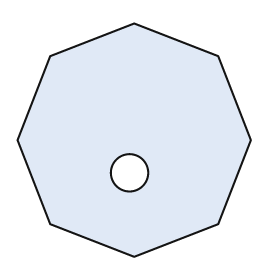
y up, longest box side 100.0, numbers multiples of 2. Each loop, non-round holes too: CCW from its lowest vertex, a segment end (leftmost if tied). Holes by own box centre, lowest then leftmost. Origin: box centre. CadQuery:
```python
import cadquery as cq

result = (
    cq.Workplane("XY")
    .moveTo(0.0, -50.0)
    .lineTo(36.0, -36.0)
    .lineTo(50.0, 0.0)
    .lineTo(36.0, 36.0)
    .lineTo(0.0, 50.0)
    .lineTo(-36.0, 36.0)
    .lineTo(-50.0, 0.0)
    .lineTo(-36.0, -36.0)
    .close()
    .moveTo(-2.0, -14.0)
    .circle(8.0)
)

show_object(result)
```